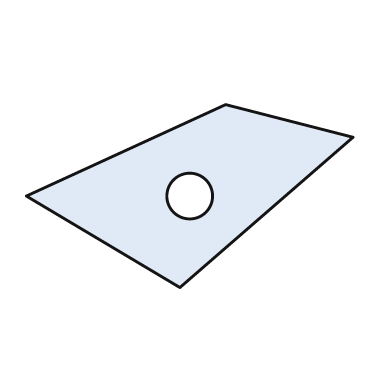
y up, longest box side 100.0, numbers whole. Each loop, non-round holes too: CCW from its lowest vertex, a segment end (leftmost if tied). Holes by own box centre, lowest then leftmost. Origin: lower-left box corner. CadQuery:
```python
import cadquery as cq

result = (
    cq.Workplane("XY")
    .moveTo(47.0, 0.0)
    .lineTo(100.0, 46.0)
    .lineTo(61.0, 56.0)
    .lineTo(0.0, 28.0)
    .close()
    .moveTo(50.0, 28.0)
    .circle(7.0)
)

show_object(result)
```